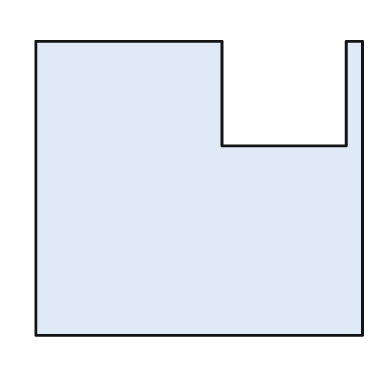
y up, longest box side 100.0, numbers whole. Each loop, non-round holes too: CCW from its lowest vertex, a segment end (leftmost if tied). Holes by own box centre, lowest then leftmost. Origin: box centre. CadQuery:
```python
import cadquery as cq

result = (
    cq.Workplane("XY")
    .moveTo(-50.0, -45.0)
    .lineTo(50.0, -45.0)
    .lineTo(50.0, 45.0)
    .lineTo(45.0, 45.0)
    .lineTo(45.0, 13.0)
    .lineTo(7.0, 13.0)
    .lineTo(7.0, 45.0)
    .lineTo(-50.0, 45.0)
    .close()
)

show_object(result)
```